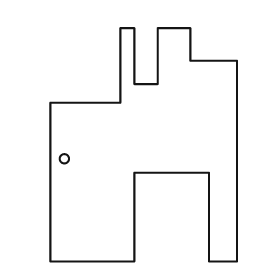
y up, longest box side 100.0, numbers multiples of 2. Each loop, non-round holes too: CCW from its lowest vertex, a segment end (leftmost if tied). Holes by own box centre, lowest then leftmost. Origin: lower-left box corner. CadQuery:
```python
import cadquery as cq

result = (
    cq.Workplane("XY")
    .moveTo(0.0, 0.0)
    .lineTo(36.0, 0.0)
    .lineTo(36.0, 38.0)
    .lineTo(68.0, 38.0)
    .lineTo(68.0, 0.0)
    .lineTo(80.0, 0.0)
    .lineTo(80.0, 86.0)
    .lineTo(60.0, 86.0)
    .lineTo(60.0, 100.0)
    .lineTo(46.0, 100.0)
    .lineTo(46.0, 76.0)
    .lineTo(36.0, 76.0)
    .lineTo(36.0, 100.0)
    .lineTo(30.0, 100.0)
    .lineTo(30.0, 68.0)
    .lineTo(0.0, 68.0)
    .close()
    .moveTo(6.0, 44.0)
    .circle(2.0)
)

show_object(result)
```